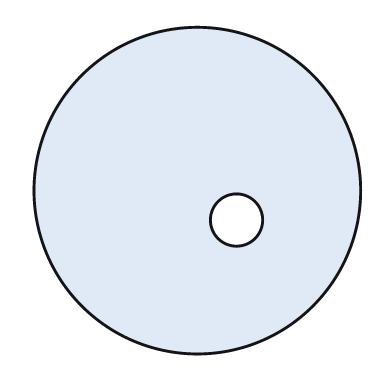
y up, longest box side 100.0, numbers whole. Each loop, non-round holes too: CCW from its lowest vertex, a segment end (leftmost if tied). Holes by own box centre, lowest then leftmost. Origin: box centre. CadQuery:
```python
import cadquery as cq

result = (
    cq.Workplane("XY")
    .moveTo(0.0, 0.0)
    .circle(50.0)
    .moveTo(12.0, -9.0)
    .circle(8.0)
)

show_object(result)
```